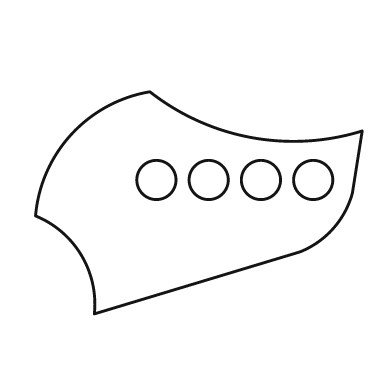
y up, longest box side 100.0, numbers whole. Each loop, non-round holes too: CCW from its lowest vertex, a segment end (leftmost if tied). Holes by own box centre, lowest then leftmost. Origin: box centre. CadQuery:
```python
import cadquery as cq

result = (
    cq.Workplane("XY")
    .moveTo(-32.0, -34.0)
    .lineTo(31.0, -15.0)
    .threePointArc((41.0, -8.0), (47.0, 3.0))
    .lineTo(50.0, 22.0)
    .threePointArc((16.0, 20.0), (-15.0, 34.0))
    .threePointArc((-39.0, 21.0), (-50.0, -4.0))
    .threePointArc((-36.0, -16.0), (-32.0, -34.0))
    .close()
    .moveTo(-13.0, 7.0)
    .circle(6.0)
    .moveTo(3.0, 7.0)
    .circle(6.0)
    .moveTo(19.0, 7.0)
    .circle(6.0)
    .moveTo(35.0, 7.0)
    .circle(6.0)
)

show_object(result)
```